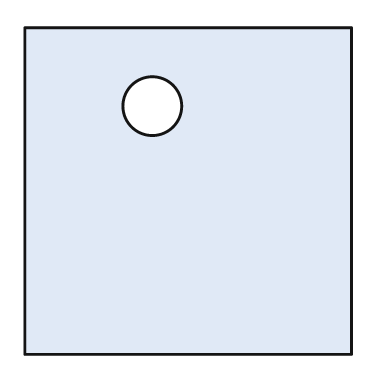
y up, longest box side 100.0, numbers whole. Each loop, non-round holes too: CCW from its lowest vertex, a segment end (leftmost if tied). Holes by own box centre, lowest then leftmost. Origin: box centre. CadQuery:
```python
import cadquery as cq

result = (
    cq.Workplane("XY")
    .moveTo(-50.0, -50.0)
    .lineTo(50.0, -50.0)
    .lineTo(50.0, 50.0)
    .lineTo(-50.0, 50.0)
    .close()
    .moveTo(-11.0, 26.0)
    .circle(9.0)
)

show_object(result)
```